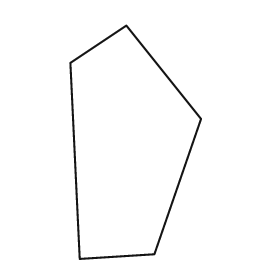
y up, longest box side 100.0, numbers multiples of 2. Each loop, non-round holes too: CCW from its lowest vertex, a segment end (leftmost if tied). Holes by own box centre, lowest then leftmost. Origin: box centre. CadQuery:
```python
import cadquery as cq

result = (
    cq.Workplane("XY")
    .moveTo(-24.0, -50.0)
    .lineTo(8.0, -48.0)
    .lineTo(28.0, 10.0)
    .lineTo(-4.0, 50.0)
    .lineTo(-28.0, 34.0)
    .close()
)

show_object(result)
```